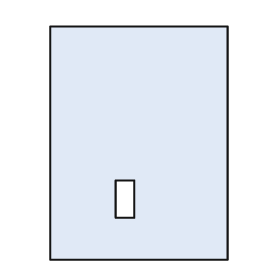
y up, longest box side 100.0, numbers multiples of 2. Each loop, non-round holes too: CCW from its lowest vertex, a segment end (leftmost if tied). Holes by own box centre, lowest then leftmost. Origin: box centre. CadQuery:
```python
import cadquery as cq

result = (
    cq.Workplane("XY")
    .moveTo(-38.0, -50.0)
    .lineTo(38.0, -50.0)
    .lineTo(38.0, 50.0)
    .lineTo(-38.0, 50.0)
    .close()
    .moveTo(-10.0, -32.0)
    .lineTo(-2.0, -32.0)
    .lineTo(-2.0, -16.0)
    .lineTo(-10.0, -16.0)
    .close()
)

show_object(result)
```